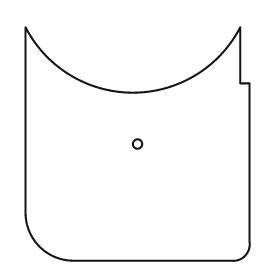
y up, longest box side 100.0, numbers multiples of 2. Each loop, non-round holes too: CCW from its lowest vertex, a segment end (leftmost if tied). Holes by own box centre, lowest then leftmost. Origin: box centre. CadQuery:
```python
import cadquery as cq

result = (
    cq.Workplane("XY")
    .moveTo(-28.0, -50.0)
    .lineTo(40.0, -50.0)
    .threePointArc((46.0, -48.0), (48.0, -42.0))
    .lineTo(48.0, 26.0)
    .lineTo(44.0, 26.0)
    .lineTo(44.0, 50.0)
    .threePointArc((-2.0, 22.0), (-48.0, 50.0))
    .lineTo(-48.0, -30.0)
    .threePointArc((-42.0, -44.0), (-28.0, -50.0))
    .close()
    .moveTo(0.0, 0.0)
    .circle(2.0)
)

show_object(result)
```